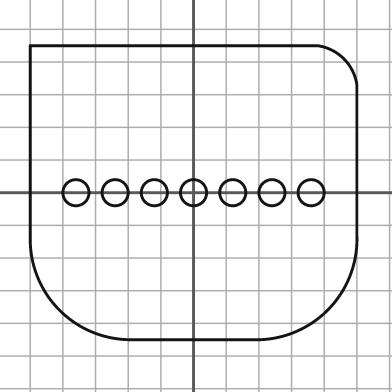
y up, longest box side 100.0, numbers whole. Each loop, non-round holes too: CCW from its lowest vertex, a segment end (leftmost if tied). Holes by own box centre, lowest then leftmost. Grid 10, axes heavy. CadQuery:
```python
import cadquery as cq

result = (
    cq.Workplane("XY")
    .moveTo(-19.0, -45.0)
    .lineTo(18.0, -45.0)
    .threePointArc((41.0, -36.0), (50.0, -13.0))
    .lineTo(50.0, 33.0)
    .threePointArc((46.0, 41.0), (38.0, 45.0))
    .lineTo(-50.0, 45.0)
    .lineTo(-50.0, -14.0)
    .threePointArc((-41.0, -36.0), (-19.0, -45.0))
    .close()
    .moveTo(-36.0, 0.0)
    .circle(4.0)
    .moveTo(-24.0, 0.0)
    .circle(4.0)
    .moveTo(-12.0, 0.0)
    .circle(4.0)
    .moveTo(0.0, 0.0)
    .circle(4.0)
    .moveTo(12.0, 0.0)
    .circle(4.0)
    .moveTo(24.0, 0.0)
    .circle(4.0)
    .moveTo(36.0, 0.0)
    .circle(4.0)
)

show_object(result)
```